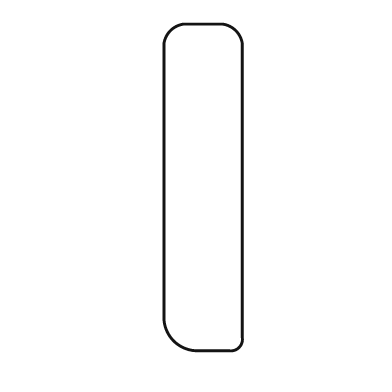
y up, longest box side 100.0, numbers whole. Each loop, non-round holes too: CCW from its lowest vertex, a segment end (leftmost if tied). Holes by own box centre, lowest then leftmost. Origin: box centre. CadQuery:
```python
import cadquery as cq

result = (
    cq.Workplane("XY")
    .moveTo(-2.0, -50.0)
    .lineTo(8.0, -50.0)
    .threePointArc((11.0, -49.0), (12.0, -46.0))
    .lineTo(12.0, 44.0)
    .threePointArc((10.0, 48.0), (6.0, 50.0))
    .lineTo(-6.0, 50.0)
    .threePointArc((-10.0, 48.0), (-12.0, 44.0))
    .lineTo(-12.0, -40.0)
    .threePointArc((-9.0, -47.0), (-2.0, -50.0))
    .close()
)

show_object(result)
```